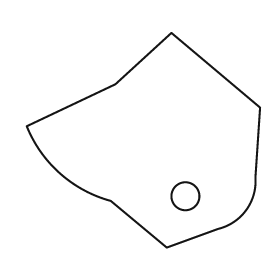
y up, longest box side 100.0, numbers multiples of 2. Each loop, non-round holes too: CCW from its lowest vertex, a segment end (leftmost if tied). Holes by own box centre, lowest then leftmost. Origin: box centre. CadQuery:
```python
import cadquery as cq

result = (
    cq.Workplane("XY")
    .moveTo(10.0, -46.0)
    .lineTo(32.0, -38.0)
    .threePointArc((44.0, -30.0), (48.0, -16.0))
    .lineTo(50.0, 14.0)
    .lineTo(12.0, 46.0)
    .lineTo(-12.0, 24.0)
    .lineTo(-50.0, 6.0)
    .threePointArc((-36.0, -14.0), (-14.0, -26.0))
    .close()
    .moveTo(18.0, -24.0)
    .circle(6.0)
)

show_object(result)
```